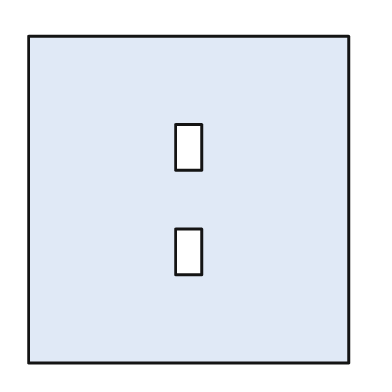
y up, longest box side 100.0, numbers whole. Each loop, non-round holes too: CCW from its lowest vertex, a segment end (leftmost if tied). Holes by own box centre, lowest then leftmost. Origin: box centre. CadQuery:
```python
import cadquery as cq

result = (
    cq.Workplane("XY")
    .moveTo(-49.0, -50.0)
    .lineTo(49.0, -50.0)
    .lineTo(49.0, 50.0)
    .lineTo(-49.0, 50.0)
    .close()
    .moveTo(-4.0, -23.0)
    .lineTo(4.0, -23.0)
    .lineTo(4.0, -9.0)
    .lineTo(-4.0, -9.0)
    .close()
    .moveTo(-4.0, 9.0)
    .lineTo(4.0, 9.0)
    .lineTo(4.0, 23.0)
    .lineTo(-4.0, 23.0)
    .close()
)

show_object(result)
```